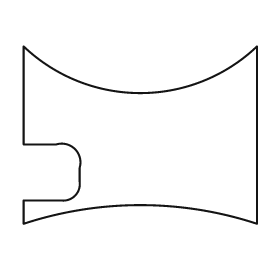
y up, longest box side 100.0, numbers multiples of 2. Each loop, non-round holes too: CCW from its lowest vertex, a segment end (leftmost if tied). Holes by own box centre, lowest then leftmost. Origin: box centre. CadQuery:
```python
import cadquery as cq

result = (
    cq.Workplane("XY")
    .moveTo(-50.0, -38.0)
    .threePointArc((0.0, -30.0), (50.0, -38.0))
    .lineTo(50.0, 38.0)
    .threePointArc((0.0, 18.0), (-50.0, 38.0))
    .lineTo(-50.0, -4.0)
    .lineTo(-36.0, -4.0)
    .threePointArc((-28.0, -6.0), (-26.0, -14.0))
    .lineTo(-26.0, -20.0)
    .threePointArc((-28.0, -26.0), (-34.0, -28.0))
    .lineTo(-50.0, -28.0)
    .close()
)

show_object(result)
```